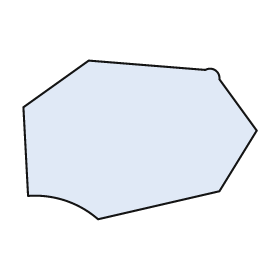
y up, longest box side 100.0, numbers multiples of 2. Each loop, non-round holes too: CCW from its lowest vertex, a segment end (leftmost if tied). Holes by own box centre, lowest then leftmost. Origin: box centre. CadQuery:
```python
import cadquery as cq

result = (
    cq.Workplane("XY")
    .moveTo(-18.0, -34.0)
    .lineTo(34.0, -22.0)
    .lineTo(50.0, 4.0)
    .lineTo(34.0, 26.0)
    .threePointArc((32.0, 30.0), (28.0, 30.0))
    .lineTo(-22.0, 34.0)
    .lineTo(-50.0, 14.0)
    .lineTo(-48.0, -24.0)
    .threePointArc((-32.0, -26.0), (-18.0, -34.0))
    .close()
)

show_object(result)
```